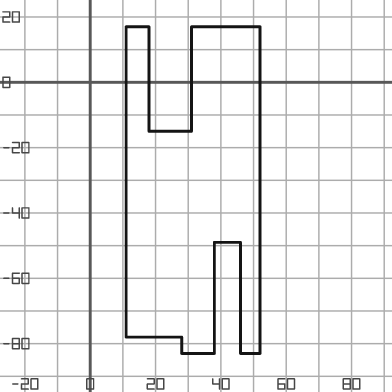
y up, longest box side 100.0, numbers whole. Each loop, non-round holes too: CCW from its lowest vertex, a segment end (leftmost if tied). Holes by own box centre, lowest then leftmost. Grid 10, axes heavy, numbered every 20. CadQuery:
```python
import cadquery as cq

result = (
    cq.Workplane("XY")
    .moveTo(28.0, -83.0)
    .lineTo(38.0, -83.0)
    .lineTo(38.0, -49.0)
    .lineTo(46.0, -49.0)
    .lineTo(46.0, -83.0)
    .lineTo(52.0, -83.0)
    .lineTo(52.0, 17.0)
    .lineTo(31.0, 17.0)
    .lineTo(31.0, -15.0)
    .lineTo(18.0, -15.0)
    .lineTo(18.0, 17.0)
    .lineTo(11.0, 17.0)
    .lineTo(11.0, -78.0)
    .lineTo(28.0, -78.0)
    .close()
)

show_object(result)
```